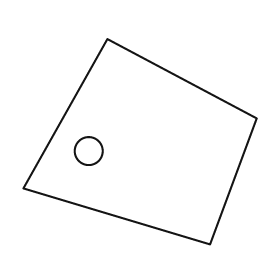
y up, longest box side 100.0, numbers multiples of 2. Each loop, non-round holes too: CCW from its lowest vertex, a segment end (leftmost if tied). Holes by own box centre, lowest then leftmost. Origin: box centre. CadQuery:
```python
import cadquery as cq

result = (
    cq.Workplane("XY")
    .moveTo(30.0, -44.0)
    .lineTo(50.0, 10.0)
    .lineTo(-14.0, 44.0)
    .lineTo(-50.0, -20.0)
    .close()
    .moveTo(-22.0, -4.0)
    .circle(6.0)
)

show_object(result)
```